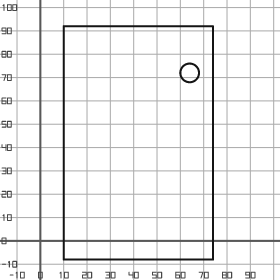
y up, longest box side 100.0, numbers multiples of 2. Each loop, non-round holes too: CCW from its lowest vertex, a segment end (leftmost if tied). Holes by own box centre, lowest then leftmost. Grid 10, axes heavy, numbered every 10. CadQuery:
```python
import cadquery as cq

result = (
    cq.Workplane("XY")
    .moveTo(10.0, -8.0)
    .lineTo(74.0, -8.0)
    .lineTo(74.0, 92.0)
    .lineTo(10.0, 92.0)
    .close()
    .moveTo(64.0, 72.0)
    .circle(4.0)
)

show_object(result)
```